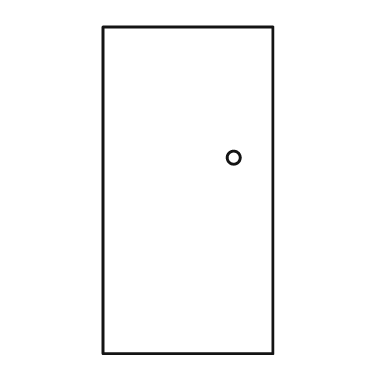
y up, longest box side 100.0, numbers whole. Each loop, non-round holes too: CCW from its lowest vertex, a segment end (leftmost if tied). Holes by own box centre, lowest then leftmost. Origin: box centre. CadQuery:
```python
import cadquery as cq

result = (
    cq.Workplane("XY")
    .moveTo(-26.0, -50.0)
    .lineTo(26.0, -50.0)
    .lineTo(26.0, 50.0)
    .lineTo(-26.0, 50.0)
    .close()
    .moveTo(14.0, 10.0)
    .circle(2.0)
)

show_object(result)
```